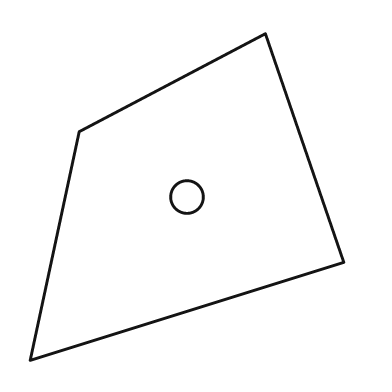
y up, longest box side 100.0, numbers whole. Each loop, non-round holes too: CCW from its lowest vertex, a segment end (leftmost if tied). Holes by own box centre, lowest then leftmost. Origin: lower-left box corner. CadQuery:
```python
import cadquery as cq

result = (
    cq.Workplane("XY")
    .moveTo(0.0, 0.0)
    .lineTo(96.0, 30.0)
    .lineTo(72.0, 100.0)
    .lineTo(15.0, 70.0)
    .close()
    .moveTo(48.0, 50.0)
    .circle(5.0)
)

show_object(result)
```